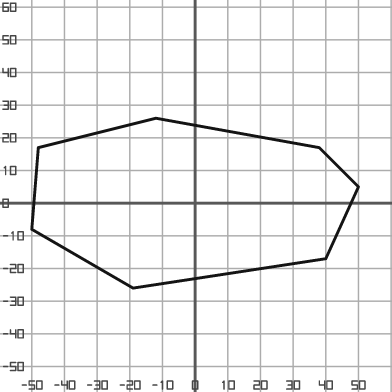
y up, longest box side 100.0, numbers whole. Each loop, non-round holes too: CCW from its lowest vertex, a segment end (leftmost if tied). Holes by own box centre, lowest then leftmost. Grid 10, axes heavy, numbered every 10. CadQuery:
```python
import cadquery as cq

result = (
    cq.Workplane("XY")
    .moveTo(-19.0, -26.0)
    .lineTo(40.0, -17.0)
    .lineTo(50.0, 5.0)
    .lineTo(38.0, 17.0)
    .lineTo(-12.0, 26.0)
    .lineTo(-48.0, 17.0)
    .lineTo(-50.0, -8.0)
    .close()
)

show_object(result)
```